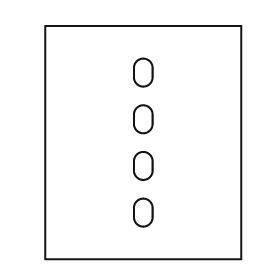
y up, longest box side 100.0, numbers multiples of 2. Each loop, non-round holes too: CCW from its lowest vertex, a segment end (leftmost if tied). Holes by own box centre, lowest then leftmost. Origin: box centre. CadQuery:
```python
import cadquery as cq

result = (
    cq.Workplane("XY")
    .moveTo(-42.0, -50.0)
    .lineTo(42.0, -50.0)
    .lineTo(42.0, 50.0)
    .lineTo(-42.0, 50.0)
    .close()
    .moveTo(-4.0, -32.0)
    .threePointArc((0.0, -36.0), (4.0, -32.0))
    .lineTo(4.0, -28.0)
    .threePointArc((0.0, -24.0), (-4.0, -28.0))
    .close()
    .moveTo(-4.0, -12.0)
    .threePointArc((0.0, -16.0), (4.0, -12.0))
    .lineTo(4.0, -8.0)
    .threePointArc((0.0, -4.0), (-4.0, -8.0))
    .close()
    .moveTo(-4.0, 8.0)
    .threePointArc((0.0, 4.0), (4.0, 8.0))
    .lineTo(4.0, 12.0)
    .threePointArc((0.0, 16.0), (-4.0, 12.0))
    .close()
    .moveTo(-4.0, 28.0)
    .threePointArc((0.0, 24.0), (4.0, 28.0))
    .lineTo(4.0, 32.0)
    .threePointArc((0.0, 36.0), (-4.0, 32.0))
    .close()
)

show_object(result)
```